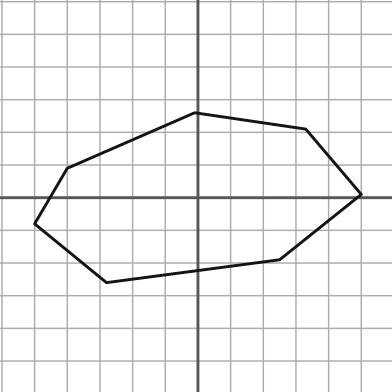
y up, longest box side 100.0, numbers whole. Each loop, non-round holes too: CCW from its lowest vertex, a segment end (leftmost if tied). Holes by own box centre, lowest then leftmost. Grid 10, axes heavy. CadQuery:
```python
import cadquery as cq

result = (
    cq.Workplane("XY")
    .moveTo(-28.0, -26.0)
    .lineTo(25.0, -19.0)
    .lineTo(50.0, 1.0)
    .lineTo(33.0, 21.0)
    .lineTo(-1.0, 26.0)
    .lineTo(-40.0, 9.0)
    .lineTo(-50.0, -8.0)
    .close()
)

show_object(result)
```